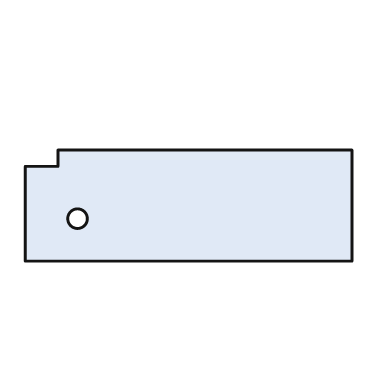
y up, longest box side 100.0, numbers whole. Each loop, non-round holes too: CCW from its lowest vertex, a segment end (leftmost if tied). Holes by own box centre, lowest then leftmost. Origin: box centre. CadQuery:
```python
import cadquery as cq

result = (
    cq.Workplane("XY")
    .moveTo(-50.0, -17.0)
    .lineTo(50.0, -17.0)
    .lineTo(50.0, 17.0)
    .lineTo(-40.0, 17.0)
    .lineTo(-40.0, 12.0)
    .lineTo(-50.0, 12.0)
    .close()
    .moveTo(-34.0, -4.0)
    .circle(3.0)
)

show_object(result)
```